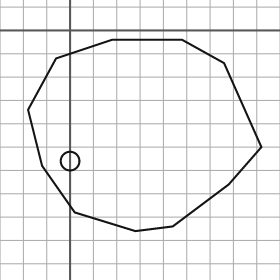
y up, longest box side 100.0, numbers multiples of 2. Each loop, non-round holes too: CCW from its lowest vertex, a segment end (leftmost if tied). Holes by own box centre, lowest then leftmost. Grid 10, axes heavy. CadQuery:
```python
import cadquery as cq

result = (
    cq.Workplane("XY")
    .moveTo(28.0, -86.0)
    .lineTo(44.0, -84.0)
    .lineTo(68.0, -66.0)
    .lineTo(82.0, -50.0)
    .lineTo(66.0, -14.0)
    .lineTo(48.0, -4.0)
    .lineTo(18.0, -4.0)
    .lineTo(-6.0, -12.0)
    .lineTo(-18.0, -34.0)
    .lineTo(-12.0, -58.0)
    .lineTo(2.0, -78.0)
    .close()
    .moveTo(0.0, -56.0)
    .circle(4.0)
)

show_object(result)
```